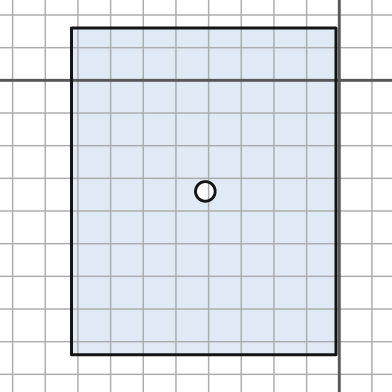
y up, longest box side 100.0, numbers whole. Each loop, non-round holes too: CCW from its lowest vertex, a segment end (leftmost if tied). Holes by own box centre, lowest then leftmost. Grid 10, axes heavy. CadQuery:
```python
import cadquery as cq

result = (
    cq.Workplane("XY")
    .moveTo(-82.0, -84.0)
    .lineTo(-1.0, -84.0)
    .lineTo(-1.0, 16.0)
    .lineTo(-82.0, 16.0)
    .close()
    .moveTo(-41.0, -34.0)
    .circle(3.0)
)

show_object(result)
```